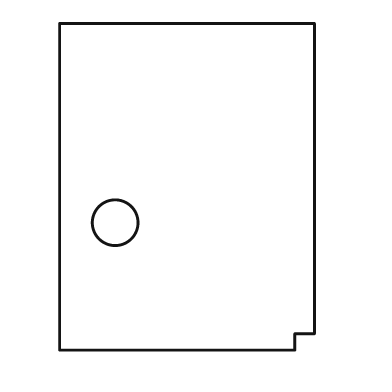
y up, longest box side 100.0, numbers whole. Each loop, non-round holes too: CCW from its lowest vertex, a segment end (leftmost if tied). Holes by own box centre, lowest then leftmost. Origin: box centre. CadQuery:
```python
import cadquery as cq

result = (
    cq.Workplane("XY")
    .moveTo(-39.0, -50.0)
    .lineTo(33.0, -50.0)
    .lineTo(33.0, -45.0)
    .lineTo(39.0, -45.0)
    .lineTo(39.0, 50.0)
    .lineTo(-39.0, 50.0)
    .close()
    .moveTo(-22.0, -11.0)
    .circle(7.0)
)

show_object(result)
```